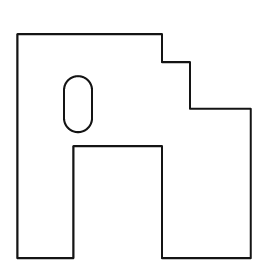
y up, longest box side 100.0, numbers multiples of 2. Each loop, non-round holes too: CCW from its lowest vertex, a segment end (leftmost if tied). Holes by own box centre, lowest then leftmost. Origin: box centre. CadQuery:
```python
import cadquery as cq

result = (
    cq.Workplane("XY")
    .moveTo(-50.0, -48.0)
    .lineTo(-26.0, -48.0)
    .lineTo(-26.0, 0.0)
    .lineTo(12.0, 0.0)
    .lineTo(12.0, -48.0)
    .lineTo(50.0, -48.0)
    .lineTo(50.0, 16.0)
    .lineTo(24.0, 16.0)
    .lineTo(24.0, 36.0)
    .lineTo(12.0, 36.0)
    .lineTo(12.0, 48.0)
    .lineTo(-50.0, 48.0)
    .close()
    .moveTo(-30.0, 12.0)
    .threePointArc((-24.0, 6.0), (-18.0, 12.0))
    .lineTo(-18.0, 24.0)
    .threePointArc((-24.0, 30.0), (-30.0, 24.0))
    .close()
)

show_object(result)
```